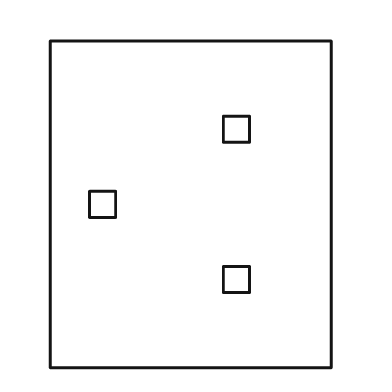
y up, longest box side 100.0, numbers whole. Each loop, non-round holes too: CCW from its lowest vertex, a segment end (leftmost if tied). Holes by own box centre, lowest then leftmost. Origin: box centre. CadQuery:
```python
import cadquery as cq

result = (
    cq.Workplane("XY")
    .moveTo(-43.0, -50.0)
    .lineTo(43.0, -50.0)
    .lineTo(43.0, 50.0)
    .lineTo(-43.0, 50.0)
    .close()
    .moveTo(10.0, -27.0)
    .lineTo(18.0, -27.0)
    .lineTo(18.0, -19.0)
    .lineTo(10.0, -19.0)
    .close()
    .moveTo(-31.0, -4.0)
    .lineTo(-23.0, -4.0)
    .lineTo(-23.0, 4.0)
    .lineTo(-31.0, 4.0)
    .close()
    .moveTo(10.0, 19.0)
    .lineTo(18.0, 19.0)
    .lineTo(18.0, 27.0)
    .lineTo(10.0, 27.0)
    .close()
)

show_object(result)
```